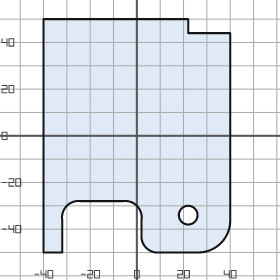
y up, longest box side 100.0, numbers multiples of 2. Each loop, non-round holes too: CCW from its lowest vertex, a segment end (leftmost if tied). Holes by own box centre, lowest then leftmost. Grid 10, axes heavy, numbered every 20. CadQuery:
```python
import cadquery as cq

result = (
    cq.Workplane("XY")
    .moveTo(-40.0, -50.0)
    .lineTo(-32.0, -50.0)
    .lineTo(-32.0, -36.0)
    .threePointArc((-30.0, -30.0), (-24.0, -28.0))
    .lineTo(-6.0, -28.0)
    .threePointArc((0.0, -30.0), (2.0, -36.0))
    .lineTo(2.0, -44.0)
    .threePointArc((4.0, -48.0), (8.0, -50.0))
    .lineTo(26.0, -50.0)
    .threePointArc((36.0, -46.0), (40.0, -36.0))
    .lineTo(40.0, 44.0)
    .lineTo(22.0, 44.0)
    .lineTo(22.0, 50.0)
    .lineTo(-40.0, 50.0)
    .close()
    .moveTo(22.0, -34.0)
    .circle(4.0)
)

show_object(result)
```